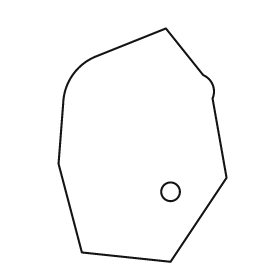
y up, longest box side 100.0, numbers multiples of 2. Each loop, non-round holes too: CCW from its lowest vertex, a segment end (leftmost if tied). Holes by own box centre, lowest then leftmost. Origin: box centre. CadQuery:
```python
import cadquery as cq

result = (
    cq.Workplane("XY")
    .moveTo(12.0, -50.0)
    .lineTo(36.0, -14.0)
    .lineTo(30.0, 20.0)
    .threePointArc((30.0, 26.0), (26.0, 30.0))
    .lineTo(10.0, 50.0)
    .lineTo(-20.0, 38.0)
    .threePointArc((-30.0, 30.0), (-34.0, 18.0))
    .lineTo(-36.0, -8.0)
    .lineTo(-26.0, -46.0)
    .close()
    .moveTo(12.0, -20.0)
    .circle(4.0)
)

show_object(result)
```